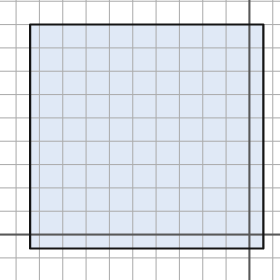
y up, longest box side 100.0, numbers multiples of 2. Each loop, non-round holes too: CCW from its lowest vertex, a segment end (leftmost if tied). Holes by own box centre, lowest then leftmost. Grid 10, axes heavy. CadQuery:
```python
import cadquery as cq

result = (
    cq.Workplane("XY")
    .moveTo(-94.0, -6.0)
    .lineTo(6.0, -6.0)
    .lineTo(6.0, 90.0)
    .lineTo(-94.0, 90.0)
    .close()
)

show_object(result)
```